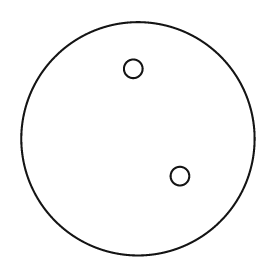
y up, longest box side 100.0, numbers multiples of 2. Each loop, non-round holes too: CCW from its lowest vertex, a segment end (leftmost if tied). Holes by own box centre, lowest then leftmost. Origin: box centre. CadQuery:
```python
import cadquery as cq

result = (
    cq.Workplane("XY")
    .moveTo(0.0, 0.0)
    .circle(50.0)
    .moveTo(18.0, -16.0)
    .circle(4.0)
    .moveTo(-2.0, 30.0)
    .circle(4.0)
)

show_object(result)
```